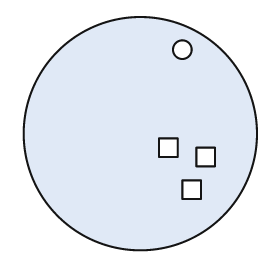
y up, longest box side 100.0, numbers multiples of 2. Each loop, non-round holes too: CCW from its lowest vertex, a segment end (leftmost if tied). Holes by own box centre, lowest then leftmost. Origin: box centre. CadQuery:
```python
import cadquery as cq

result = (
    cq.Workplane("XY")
    .moveTo(0.0, 0.0)
    .circle(50.0)
    .moveTo(18.0, -28.0)
    .lineTo(26.0, -28.0)
    .lineTo(26.0, -20.0)
    .lineTo(18.0, -20.0)
    .close()
    .moveTo(24.0, -14.0)
    .lineTo(32.0, -14.0)
    .lineTo(32.0, -6.0)
    .lineTo(24.0, -6.0)
    .close()
    .moveTo(8.0, -10.0)
    .lineTo(16.0, -10.0)
    .lineTo(16.0, -2.0)
    .lineTo(8.0, -2.0)
    .close()
    .moveTo(18.0, 36.0)
    .circle(4.0)
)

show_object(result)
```